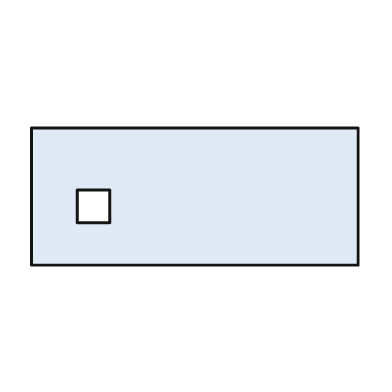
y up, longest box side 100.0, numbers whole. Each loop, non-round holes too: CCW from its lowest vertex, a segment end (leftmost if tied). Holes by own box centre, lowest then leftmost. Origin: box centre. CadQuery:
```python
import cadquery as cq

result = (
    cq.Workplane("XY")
    .moveTo(-50.0, -21.0)
    .lineTo(50.0, -21.0)
    .lineTo(50.0, 21.0)
    .lineTo(-50.0, 21.0)
    .close()
    .moveTo(-36.0, -8.0)
    .lineTo(-26.0, -8.0)
    .lineTo(-26.0, 2.0)
    .lineTo(-36.0, 2.0)
    .close()
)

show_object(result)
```